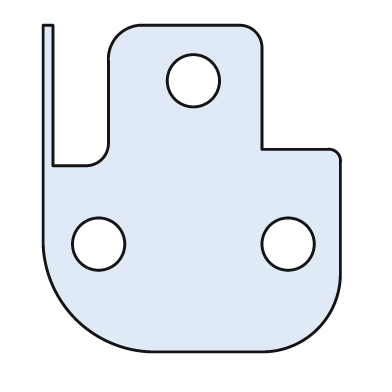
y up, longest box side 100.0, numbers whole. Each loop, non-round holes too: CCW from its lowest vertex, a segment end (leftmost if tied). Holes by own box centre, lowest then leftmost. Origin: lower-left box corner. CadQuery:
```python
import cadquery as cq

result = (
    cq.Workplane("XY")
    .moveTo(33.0, 0.0)
    .lineTo(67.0, 0.0)
    .threePointArc((84.0, 7.0), (91.0, 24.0))
    .lineTo(91.0, 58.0)
    .threePointArc((90.0, 61.0), (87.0, 62.0))
    .lineTo(67.0, 62.0)
    .lineTo(67.0, 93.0)
    .threePointArc((65.0, 98.0), (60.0, 100.0))
    .lineTo(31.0, 100.0)
    .threePointArc((23.0, 97.0), (20.0, 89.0))
    .lineTo(20.0, 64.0)
    .threePointArc((18.0, 59.0), (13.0, 57.0))
    .lineTo(3.0, 57.0)
    .lineTo(3.0, 100.0)
    .lineTo(0.0, 100.0)
    .lineTo(0.0, 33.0)
    .threePointArc((10.0, 10.0), (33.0, 0.0))
    .close()
    .moveTo(17.0, 33.0)
    .circle(8.0)
    .moveTo(75.0, 33.0)
    .circle(8.0)
    .moveTo(46.0, 83.0)
    .circle(8.0)
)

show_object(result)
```